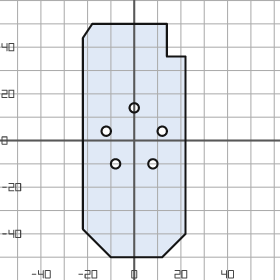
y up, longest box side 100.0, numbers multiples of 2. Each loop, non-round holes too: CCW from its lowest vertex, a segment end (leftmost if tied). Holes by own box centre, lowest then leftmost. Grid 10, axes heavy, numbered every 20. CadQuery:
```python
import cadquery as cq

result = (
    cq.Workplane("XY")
    .moveTo(-10.0, -50.0)
    .lineTo(12.0, -50.0)
    .lineTo(22.0, -40.0)
    .lineTo(22.0, 36.0)
    .lineTo(14.0, 36.0)
    .lineTo(14.0, 50.0)
    .lineTo(-18.0, 50.0)
    .lineTo(-22.0, 44.0)
    .lineTo(-22.0, -38.0)
    .close()
    .moveTo(-8.0, -10.0)
    .circle(2.0)
    .moveTo(8.0, -10.0)
    .circle(2.0)
    .moveTo(-12.0, 4.0)
    .circle(2.0)
    .moveTo(12.0, 4.0)
    .circle(2.0)
    .moveTo(0.0, 14.0)
    .circle(2.0)
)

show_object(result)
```